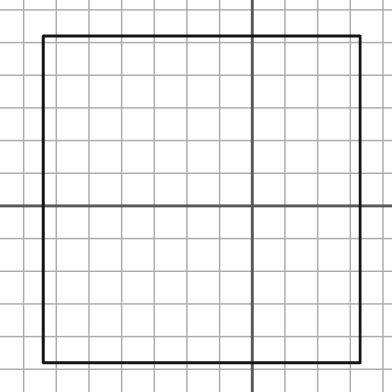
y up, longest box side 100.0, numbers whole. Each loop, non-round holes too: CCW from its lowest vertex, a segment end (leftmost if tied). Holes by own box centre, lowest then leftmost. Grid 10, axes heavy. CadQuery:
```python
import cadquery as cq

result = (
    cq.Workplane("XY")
    .moveTo(-64.0, -48.0)
    .lineTo(33.0, -48.0)
    .lineTo(33.0, 52.0)
    .lineTo(-64.0, 52.0)
    .close()
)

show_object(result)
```